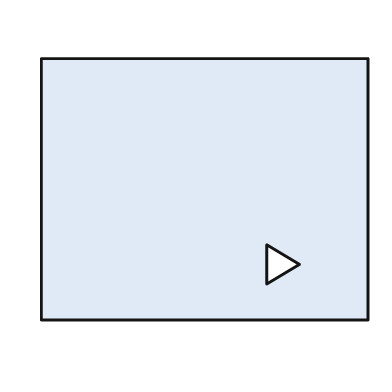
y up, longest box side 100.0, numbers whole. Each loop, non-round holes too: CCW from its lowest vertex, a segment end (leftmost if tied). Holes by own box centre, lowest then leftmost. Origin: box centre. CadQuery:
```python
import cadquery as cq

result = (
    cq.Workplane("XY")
    .moveTo(-50.0, -40.0)
    .lineTo(50.0, -40.0)
    .lineTo(50.0, 40.0)
    .lineTo(-50.0, 40.0)
    .close()
    .moveTo(19.0, -29.0)
    .lineTo(29.0, -23.0)
    .lineTo(19.0, -17.0)
    .close()
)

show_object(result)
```